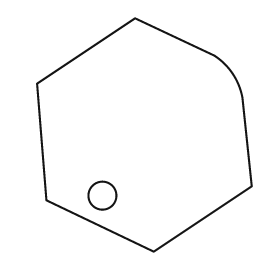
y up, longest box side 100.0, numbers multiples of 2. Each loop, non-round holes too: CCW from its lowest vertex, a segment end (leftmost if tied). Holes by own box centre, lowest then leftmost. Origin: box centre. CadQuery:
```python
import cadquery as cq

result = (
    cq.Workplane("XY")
    .moveTo(4.0, -50.0)
    .lineTo(46.0, -22.0)
    .lineTo(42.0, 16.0)
    .threePointArc((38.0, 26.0), (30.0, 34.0))
    .lineTo(-4.0, 50.0)
    .lineTo(-46.0, 22.0)
    .lineTo(-42.0, -28.0)
    .close()
    .moveTo(-18.0, -26.0)
    .circle(6.0)
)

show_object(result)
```